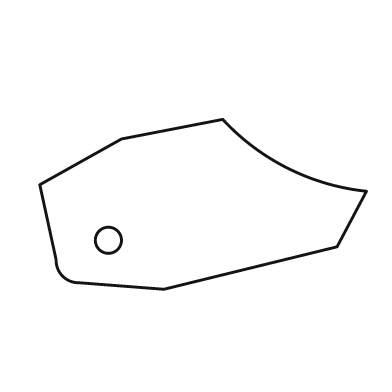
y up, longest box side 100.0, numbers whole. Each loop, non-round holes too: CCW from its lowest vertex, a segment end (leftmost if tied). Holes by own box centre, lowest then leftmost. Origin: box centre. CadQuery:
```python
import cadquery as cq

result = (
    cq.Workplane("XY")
    .moveTo(-12.0, -26.0)
    .lineTo(41.0, -13.0)
    .lineTo(50.0, 4.0)
    .threePointArc((26.0, 11.0), (6.0, 26.0))
    .lineTo(-25.0, 20.0)
    .lineTo(-50.0, 6.0)
    .lineTo(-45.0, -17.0)
    .threePointArc((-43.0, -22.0), (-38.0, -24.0))
    .close()
    .moveTo(-29.0, -11.0)
    .circle(4.0)
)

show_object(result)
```